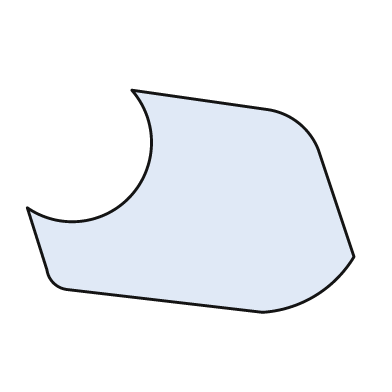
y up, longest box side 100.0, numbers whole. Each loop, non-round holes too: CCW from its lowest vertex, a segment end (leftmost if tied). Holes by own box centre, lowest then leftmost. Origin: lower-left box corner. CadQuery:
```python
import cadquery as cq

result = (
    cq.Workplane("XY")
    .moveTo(72.0, 0.0)
    .threePointArc((88.0, 5.0), (100.0, 17.0))
    .lineTo(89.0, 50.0)
    .threePointArc((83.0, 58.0), (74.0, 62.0))
    .lineTo(32.0, 68.0)
    .threePointArc((32.0, 36.0), (0.0, 32.0))
    .lineTo(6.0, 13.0)
    .threePointArc((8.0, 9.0), (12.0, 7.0))
    .close()
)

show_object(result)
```